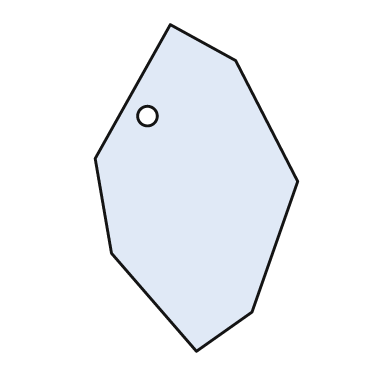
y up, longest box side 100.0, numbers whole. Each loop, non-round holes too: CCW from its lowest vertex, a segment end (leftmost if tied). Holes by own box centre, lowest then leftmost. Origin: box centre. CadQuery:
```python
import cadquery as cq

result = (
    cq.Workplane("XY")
    .moveTo(0.0, -50.0)
    .lineTo(17.0, -38.0)
    .lineTo(31.0, 2.0)
    .lineTo(12.0, 39.0)
    .lineTo(-8.0, 50.0)
    .lineTo(-31.0, 9.0)
    .lineTo(-26.0, -20.0)
    .close()
    .moveTo(-15.0, 22.0)
    .circle(3.0)
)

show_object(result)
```